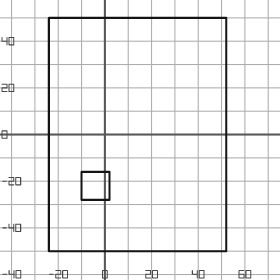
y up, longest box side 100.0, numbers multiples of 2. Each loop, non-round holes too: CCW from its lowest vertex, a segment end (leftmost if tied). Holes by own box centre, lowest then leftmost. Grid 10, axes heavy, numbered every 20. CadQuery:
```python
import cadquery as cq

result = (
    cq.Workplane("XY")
    .moveTo(-24.0, -50.0)
    .lineTo(52.0, -50.0)
    .lineTo(52.0, 50.0)
    .lineTo(-24.0, 50.0)
    .close()
    .moveTo(-10.0, -28.0)
    .lineTo(2.0, -28.0)
    .lineTo(2.0, -16.0)
    .lineTo(-10.0, -16.0)
    .close()
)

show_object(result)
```